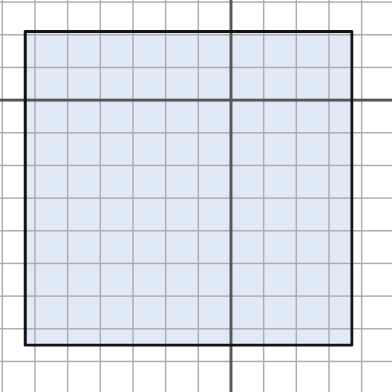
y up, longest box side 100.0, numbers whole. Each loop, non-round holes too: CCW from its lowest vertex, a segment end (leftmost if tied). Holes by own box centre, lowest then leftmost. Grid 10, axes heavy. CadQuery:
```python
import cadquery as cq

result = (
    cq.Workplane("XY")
    .moveTo(-63.0, -75.0)
    .lineTo(37.0, -75.0)
    .lineTo(37.0, 21.0)
    .lineTo(-63.0, 21.0)
    .close()
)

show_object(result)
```